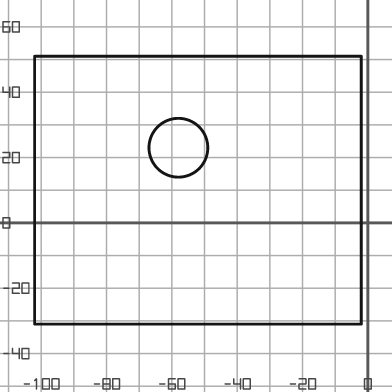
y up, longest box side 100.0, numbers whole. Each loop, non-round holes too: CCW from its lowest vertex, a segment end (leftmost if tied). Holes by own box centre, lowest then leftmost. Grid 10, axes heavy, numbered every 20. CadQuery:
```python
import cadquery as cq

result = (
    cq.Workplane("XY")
    .moveTo(-102.0, -31.0)
    .lineTo(-2.0, -31.0)
    .lineTo(-2.0, 51.0)
    .lineTo(-102.0, 51.0)
    .close()
    .moveTo(-58.0, 23.0)
    .circle(9.0)
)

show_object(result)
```